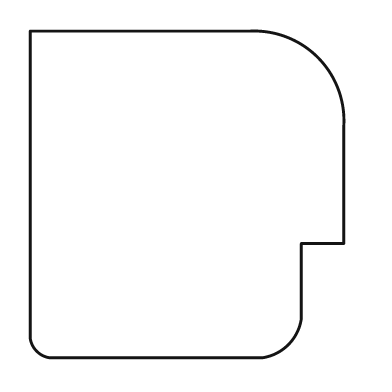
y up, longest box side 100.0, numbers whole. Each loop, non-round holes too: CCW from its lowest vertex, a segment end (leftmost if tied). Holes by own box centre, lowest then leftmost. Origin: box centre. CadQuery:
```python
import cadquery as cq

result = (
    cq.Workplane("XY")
    .moveTo(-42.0, -50.0)
    .lineTo(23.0, -50.0)
    .threePointArc((31.0, -46.0), (35.0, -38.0))
    .lineTo(35.0, -15.0)
    .lineTo(48.0, -15.0)
    .lineTo(48.0, 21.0)
    .threePointArc((40.0, 42.0), (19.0, 50.0))
    .lineTo(-48.0, 50.0)
    .lineTo(-48.0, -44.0)
    .threePointArc((-46.0, -48.0), (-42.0, -50.0))
    .close()
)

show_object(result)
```